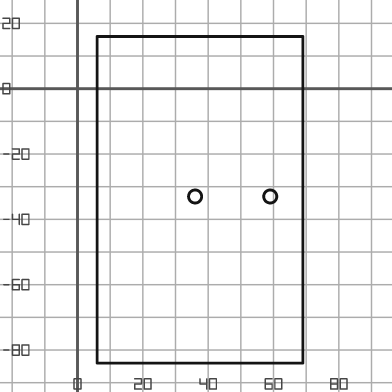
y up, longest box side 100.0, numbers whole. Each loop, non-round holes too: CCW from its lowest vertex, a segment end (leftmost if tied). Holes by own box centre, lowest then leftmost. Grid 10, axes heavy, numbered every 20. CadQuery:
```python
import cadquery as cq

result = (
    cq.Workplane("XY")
    .moveTo(6.0, -84.0)
    .lineTo(69.0, -84.0)
    .lineTo(69.0, 16.0)
    .lineTo(6.0, 16.0)
    .close()
    .moveTo(36.0, -33.0)
    .circle(2.0)
    .moveTo(59.0, -33.0)
    .circle(2.0)
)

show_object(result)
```